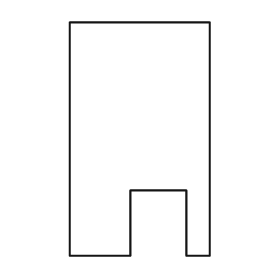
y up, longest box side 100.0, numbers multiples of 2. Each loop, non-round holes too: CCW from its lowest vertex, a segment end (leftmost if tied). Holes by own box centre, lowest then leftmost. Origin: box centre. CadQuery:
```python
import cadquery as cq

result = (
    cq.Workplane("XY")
    .moveTo(-30.0, -50.0)
    .lineTo(-4.0, -50.0)
    .lineTo(-4.0, -22.0)
    .lineTo(20.0, -22.0)
    .lineTo(20.0, -50.0)
    .lineTo(30.0, -50.0)
    .lineTo(30.0, 50.0)
    .lineTo(-30.0, 50.0)
    .close()
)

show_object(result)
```